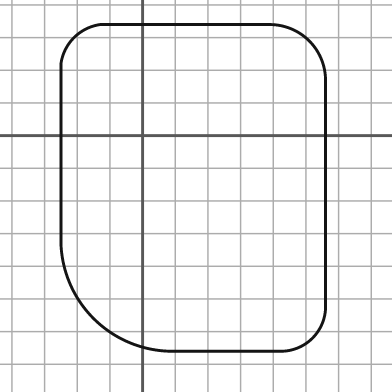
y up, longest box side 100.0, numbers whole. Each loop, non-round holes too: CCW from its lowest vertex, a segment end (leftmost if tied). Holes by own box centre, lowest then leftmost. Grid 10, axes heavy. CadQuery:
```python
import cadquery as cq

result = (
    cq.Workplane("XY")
    .moveTo(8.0, -66.0)
    .lineTo(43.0, -66.0)
    .threePointArc((52.0, -62.0), (56.0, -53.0))
    .lineTo(56.0, 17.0)
    .threePointArc((51.0, 29.0), (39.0, 34.0))
    .lineTo(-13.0, 34.0)
    .threePointArc((-21.0, 30.0), (-25.0, 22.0))
    .lineTo(-25.0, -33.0)
    .threePointArc((-15.0, -56.0), (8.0, -66.0))
    .close()
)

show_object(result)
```